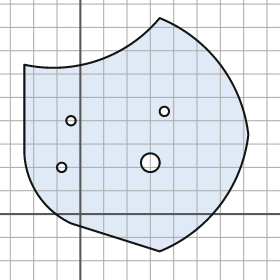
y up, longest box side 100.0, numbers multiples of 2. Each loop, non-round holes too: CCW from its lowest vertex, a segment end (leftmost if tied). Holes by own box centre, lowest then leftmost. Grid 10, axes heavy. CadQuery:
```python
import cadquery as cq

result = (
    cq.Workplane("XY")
    .moveTo(34.0, -16.0)
    .threePointArc((60.0, 4.0), (72.0, 34.0))
    .threePointArc((60.0, 64.0), (34.0, 84.0))
    .threePointArc((8.0, 66.0), (-24.0, 64.0))
    .lineTo(-24.0, 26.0)
    .threePointArc((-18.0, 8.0), (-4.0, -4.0))
    .close()
    .moveTo(-8.0, 20.0)
    .circle(2.0)
    .moveTo(30.0, 22.0)
    .circle(4.0)
    .moveTo(-4.0, 40.0)
    .circle(2.0)
    .moveTo(36.0, 44.0)
    .circle(2.0)
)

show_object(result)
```